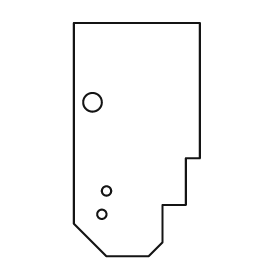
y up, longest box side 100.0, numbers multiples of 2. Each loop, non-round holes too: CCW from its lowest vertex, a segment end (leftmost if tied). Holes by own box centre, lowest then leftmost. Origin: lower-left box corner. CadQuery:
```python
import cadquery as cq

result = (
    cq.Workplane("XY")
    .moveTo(14.0, 0.0)
    .lineTo(32.0, 0.0)
    .lineTo(38.0, 6.0)
    .lineTo(38.0, 22.0)
    .lineTo(48.0, 22.0)
    .lineTo(48.0, 42.0)
    .lineTo(54.0, 42.0)
    .lineTo(54.0, 100.0)
    .lineTo(0.0, 100.0)
    .lineTo(0.0, 14.0)
    .close()
    .moveTo(12.0, 18.0)
    .circle(2.0)
    .moveTo(14.0, 28.0)
    .circle(2.0)
    .moveTo(8.0, 66.0)
    .circle(4.0)
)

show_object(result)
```